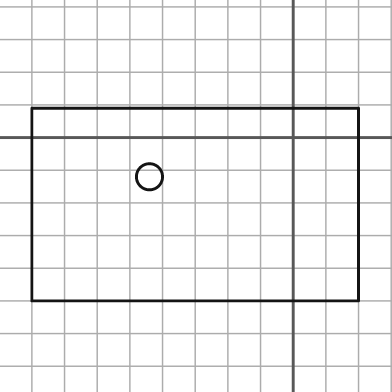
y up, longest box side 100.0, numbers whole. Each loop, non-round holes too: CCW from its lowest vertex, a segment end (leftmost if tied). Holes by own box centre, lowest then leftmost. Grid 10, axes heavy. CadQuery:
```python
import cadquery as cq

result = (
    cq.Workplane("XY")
    .moveTo(-80.0, -50.0)
    .lineTo(20.0, -50.0)
    .lineTo(20.0, 9.0)
    .lineTo(-80.0, 9.0)
    .close()
    .moveTo(-44.0, -12.0)
    .circle(4.0)
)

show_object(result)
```